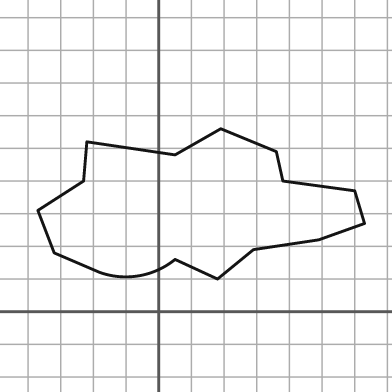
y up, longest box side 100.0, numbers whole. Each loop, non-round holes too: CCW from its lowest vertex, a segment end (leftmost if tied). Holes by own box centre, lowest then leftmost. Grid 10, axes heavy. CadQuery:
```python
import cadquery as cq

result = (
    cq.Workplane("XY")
    .moveTo(18.0, 10.0)
    .lineTo(29.0, 19.0)
    .lineTo(49.0, 22.0)
    .lineTo(63.0, 27.0)
    .lineTo(60.0, 37.0)
    .lineTo(38.0, 40.0)
    .lineTo(36.0, 49.0)
    .lineTo(19.0, 56.0)
    .lineTo(5.0, 48.0)
    .lineTo(-22.0, 52.0)
    .lineTo(-23.0, 40.0)
    .lineTo(-37.0, 31.0)
    .lineTo(-32.0, 18.0)
    .lineTo(-18.0, 12.0)
    .threePointArc((-6.0, 11.0), (5.0, 16.0))
    .close()
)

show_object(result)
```